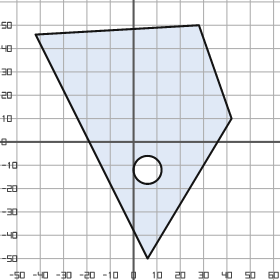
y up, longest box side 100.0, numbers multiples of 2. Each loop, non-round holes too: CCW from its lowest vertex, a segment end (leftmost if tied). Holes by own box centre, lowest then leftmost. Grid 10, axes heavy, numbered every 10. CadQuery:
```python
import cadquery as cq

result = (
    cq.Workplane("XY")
    .moveTo(6.0, -50.0)
    .lineTo(42.0, 10.0)
    .lineTo(28.0, 50.0)
    .lineTo(-42.0, 46.0)
    .close()
    .moveTo(6.0, -12.0)
    .circle(6.0)
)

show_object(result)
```